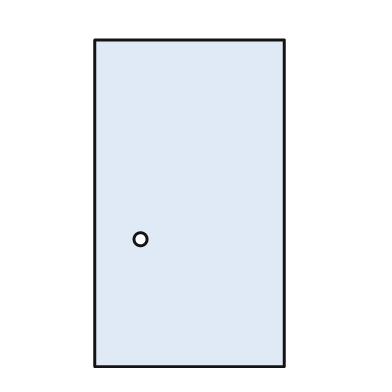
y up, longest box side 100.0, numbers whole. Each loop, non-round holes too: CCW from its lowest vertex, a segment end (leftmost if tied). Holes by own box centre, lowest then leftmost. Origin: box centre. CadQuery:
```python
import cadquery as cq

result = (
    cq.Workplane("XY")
    .moveTo(-29.0, -50.0)
    .lineTo(29.0, -50.0)
    .lineTo(29.0, 50.0)
    .lineTo(-29.0, 50.0)
    .close()
    .moveTo(-15.0, -11.0)
    .circle(2.0)
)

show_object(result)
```